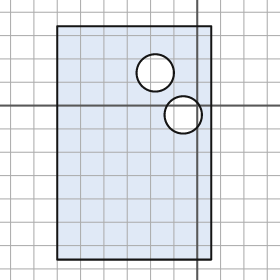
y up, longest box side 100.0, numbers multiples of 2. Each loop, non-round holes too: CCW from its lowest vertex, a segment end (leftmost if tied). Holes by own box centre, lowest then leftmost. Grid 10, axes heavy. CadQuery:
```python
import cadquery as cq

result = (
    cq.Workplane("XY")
    .moveTo(-60.0, -66.0)
    .lineTo(6.0, -66.0)
    .lineTo(6.0, 34.0)
    .lineTo(-60.0, 34.0)
    .close()
    .moveTo(-6.0, -4.0)
    .circle(8.0)
    .moveTo(-18.0, 14.0)
    .circle(8.0)
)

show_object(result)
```